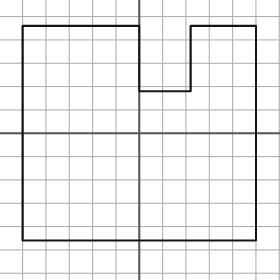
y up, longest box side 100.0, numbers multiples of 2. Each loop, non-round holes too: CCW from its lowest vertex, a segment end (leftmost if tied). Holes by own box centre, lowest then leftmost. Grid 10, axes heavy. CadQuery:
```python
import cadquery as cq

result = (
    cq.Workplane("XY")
    .moveTo(-50.0, -46.0)
    .lineTo(50.0, -46.0)
    .lineTo(50.0, 46.0)
    .lineTo(22.0, 46.0)
    .lineTo(22.0, 18.0)
    .lineTo(0.0, 18.0)
    .lineTo(0.0, 46.0)
    .lineTo(-50.0, 46.0)
    .close()
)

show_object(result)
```